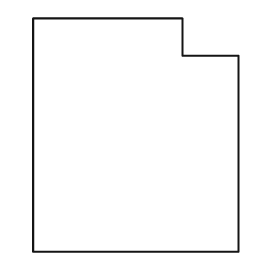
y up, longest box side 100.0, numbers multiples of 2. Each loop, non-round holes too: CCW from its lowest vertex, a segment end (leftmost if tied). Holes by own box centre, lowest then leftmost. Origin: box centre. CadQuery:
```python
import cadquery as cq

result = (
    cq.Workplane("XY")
    .moveTo(-44.0, -50.0)
    .lineTo(44.0, -50.0)
    .lineTo(44.0, 34.0)
    .lineTo(20.0, 34.0)
    .lineTo(20.0, 50.0)
    .lineTo(-44.0, 50.0)
    .close()
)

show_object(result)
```